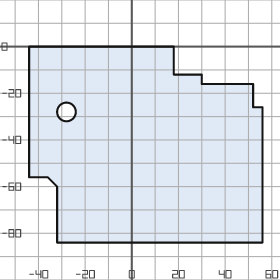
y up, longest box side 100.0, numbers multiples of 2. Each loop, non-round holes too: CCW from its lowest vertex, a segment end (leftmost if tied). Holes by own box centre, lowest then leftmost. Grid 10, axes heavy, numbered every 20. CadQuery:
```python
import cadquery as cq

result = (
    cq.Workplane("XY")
    .moveTo(-32.0, -84.0)
    .lineTo(56.0, -84.0)
    .lineTo(56.0, -26.0)
    .lineTo(52.0, -26.0)
    .lineTo(52.0, -16.0)
    .lineTo(30.0, -16.0)
    .lineTo(30.0, -12.0)
    .lineTo(18.0, -12.0)
    .lineTo(18.0, 0.0)
    .lineTo(-44.0, 0.0)
    .lineTo(-44.0, -56.0)
    .lineTo(-36.0, -56.0)
    .lineTo(-32.0, -60.0)
    .close()
    .moveTo(-28.0, -28.0)
    .circle(4.0)
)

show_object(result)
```